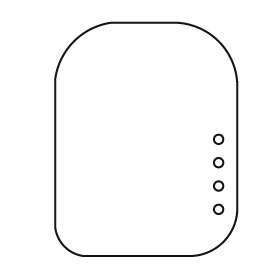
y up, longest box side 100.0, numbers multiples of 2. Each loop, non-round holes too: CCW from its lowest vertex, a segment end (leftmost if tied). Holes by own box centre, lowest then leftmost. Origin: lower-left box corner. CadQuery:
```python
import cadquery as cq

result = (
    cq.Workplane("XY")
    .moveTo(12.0, 0.0)
    .lineTo(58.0, 0.0)
    .threePointArc((72.0, 6.0), (78.0, 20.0))
    .lineTo(78.0, 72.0)
    .threePointArc((70.0, 92.0), (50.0, 100.0))
    .lineTo(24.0, 100.0)
    .threePointArc((8.0, 92.0), (0.0, 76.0))
    .lineTo(0.0, 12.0)
    .threePointArc((4.0, 4.0), (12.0, 0.0))
    .close()
    .moveTo(70.0, 20.0)
    .circle(2.0)
    .moveTo(70.0, 30.0)
    .circle(2.0)
    .moveTo(70.0, 40.0)
    .circle(2.0)
    .moveTo(70.0, 50.0)
    .circle(2.0)
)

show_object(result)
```